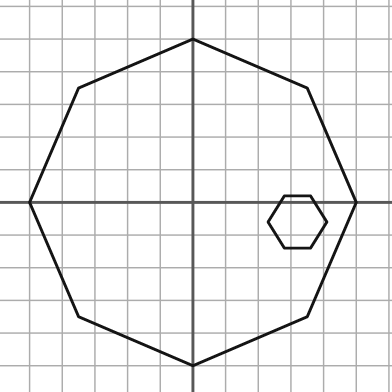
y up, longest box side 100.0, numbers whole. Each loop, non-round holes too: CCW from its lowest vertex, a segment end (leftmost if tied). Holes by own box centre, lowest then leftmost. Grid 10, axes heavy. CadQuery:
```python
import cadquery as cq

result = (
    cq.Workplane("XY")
    .moveTo(0.0, -50.0)
    .lineTo(35.0, -35.0)
    .lineTo(50.0, 0.0)
    .lineTo(35.0, 35.0)
    .lineTo(0.0, 50.0)
    .lineTo(-35.0, 35.0)
    .lineTo(-50.0, 0.0)
    .lineTo(-35.0, -35.0)
    .close()
    .moveTo(28.0, -14.0)
    .lineTo(36.0, -14.0)
    .lineTo(41.0, -6.0)
    .lineTo(36.0, 2.0)
    .lineTo(28.0, 2.0)
    .lineTo(23.0, -6.0)
    .close()
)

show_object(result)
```